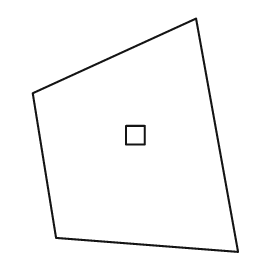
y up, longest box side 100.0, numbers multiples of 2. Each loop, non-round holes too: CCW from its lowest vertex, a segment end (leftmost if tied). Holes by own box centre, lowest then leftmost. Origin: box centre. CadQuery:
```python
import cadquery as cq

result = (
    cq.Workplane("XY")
    .moveTo(44.0, -50.0)
    .lineTo(26.0, 50.0)
    .lineTo(-44.0, 18.0)
    .lineTo(-34.0, -44.0)
    .close()
    .moveTo(-4.0, -4.0)
    .lineTo(4.0, -4.0)
    .lineTo(4.0, 4.0)
    .lineTo(-4.0, 4.0)
    .close()
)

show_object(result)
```